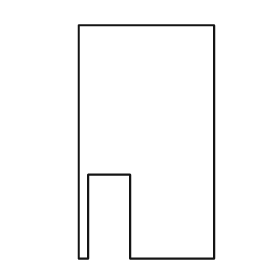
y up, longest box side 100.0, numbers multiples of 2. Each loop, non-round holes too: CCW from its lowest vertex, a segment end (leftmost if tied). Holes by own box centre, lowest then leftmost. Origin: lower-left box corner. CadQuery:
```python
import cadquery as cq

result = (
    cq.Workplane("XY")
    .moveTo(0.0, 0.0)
    .lineTo(4.0, 0.0)
    .lineTo(4.0, 36.0)
    .lineTo(22.0, 36.0)
    .lineTo(22.0, 0.0)
    .lineTo(58.0, 0.0)
    .lineTo(58.0, 100.0)
    .lineTo(0.0, 100.0)
    .close()
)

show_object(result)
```